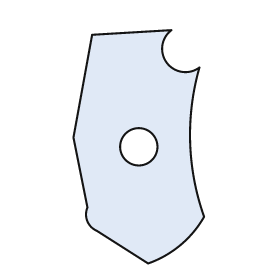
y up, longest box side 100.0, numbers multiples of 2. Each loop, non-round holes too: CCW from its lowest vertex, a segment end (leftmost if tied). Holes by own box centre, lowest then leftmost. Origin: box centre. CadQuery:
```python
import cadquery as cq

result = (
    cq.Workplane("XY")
    .moveTo(4.0, -50.0)
    .threePointArc((18.0, -42.0), (28.0, -30.0))
    .threePointArc((22.0, 2.0), (26.0, 34.0))
    .threePointArc((12.0, 36.0), (14.0, 50.0))
    .lineTo(-20.0, 48.0)
    .lineTo(-28.0, 4.0)
    .lineTo(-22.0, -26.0)
    .threePointArc((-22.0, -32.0), (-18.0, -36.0))
    .close()
    .moveTo(0.0, 0.0)
    .circle(8.0)
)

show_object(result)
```